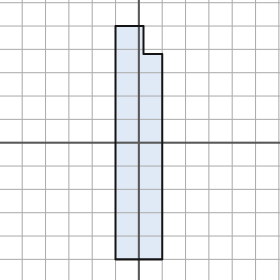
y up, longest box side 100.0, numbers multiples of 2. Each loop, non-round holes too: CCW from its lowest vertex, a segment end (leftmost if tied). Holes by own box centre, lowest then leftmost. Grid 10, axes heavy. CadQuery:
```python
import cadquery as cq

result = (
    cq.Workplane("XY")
    .moveTo(-10.0, -50.0)
    .lineTo(10.0, -50.0)
    .lineTo(10.0, 38.0)
    .lineTo(2.0, 38.0)
    .lineTo(2.0, 50.0)
    .lineTo(-10.0, 50.0)
    .close()
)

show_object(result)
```